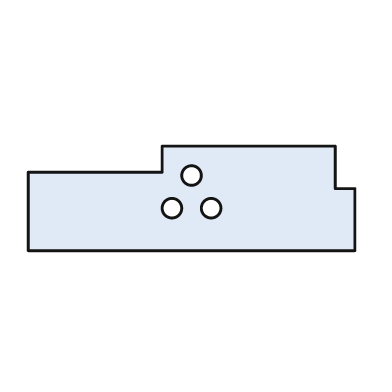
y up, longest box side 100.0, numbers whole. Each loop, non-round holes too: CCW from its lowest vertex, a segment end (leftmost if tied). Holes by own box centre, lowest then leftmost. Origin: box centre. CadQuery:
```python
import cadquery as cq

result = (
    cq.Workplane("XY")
    .moveTo(-50.0, -16.0)
    .lineTo(50.0, -16.0)
    .lineTo(50.0, 3.0)
    .lineTo(44.0, 3.0)
    .lineTo(44.0, 16.0)
    .lineTo(-9.0, 16.0)
    .lineTo(-9.0, 8.0)
    .lineTo(-50.0, 8.0)
    .close()
    .moveTo(-6.0, -3.0)
    .circle(3.0)
    .moveTo(6.0, -3.0)
    .circle(3.0)
    .moveTo(0.0, 7.0)
    .circle(3.0)
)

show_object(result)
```